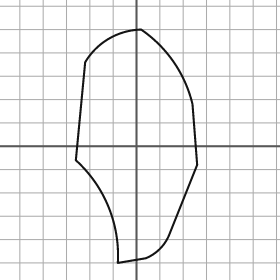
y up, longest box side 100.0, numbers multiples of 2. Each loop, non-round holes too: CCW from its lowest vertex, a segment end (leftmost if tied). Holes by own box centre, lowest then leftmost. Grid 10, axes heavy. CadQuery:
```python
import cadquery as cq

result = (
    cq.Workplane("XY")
    .moveTo(-8.0, -50.0)
    .lineTo(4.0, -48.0)
    .threePointArc((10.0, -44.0), (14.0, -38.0))
    .lineTo(26.0, -8.0)
    .lineTo(24.0, 18.0)
    .threePointArc((16.0, 36.0), (2.0, 50.0))
    .threePointArc((-12.0, 46.0), (-22.0, 36.0))
    .lineTo(-26.0, -6.0)
    .threePointArc((-12.0, -26.0), (-8.0, -50.0))
    .close()
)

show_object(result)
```